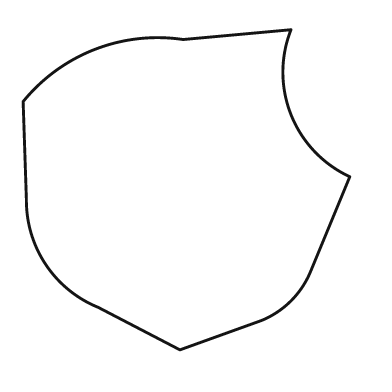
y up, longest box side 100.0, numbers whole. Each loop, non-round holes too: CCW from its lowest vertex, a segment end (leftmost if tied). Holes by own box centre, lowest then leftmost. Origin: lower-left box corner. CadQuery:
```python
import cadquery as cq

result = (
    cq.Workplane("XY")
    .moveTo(48.0, 0.0)
    .lineTo(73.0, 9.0)
    .threePointArc((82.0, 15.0), (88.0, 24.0))
    .lineTo(100.0, 53.0)
    .threePointArc((82.0, 72.0), (82.0, 98.0))
    .lineTo(49.0, 95.0)
    .threePointArc((22.0, 92.0), (0.0, 76.0))
    .lineTo(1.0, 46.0)
    .threePointArc((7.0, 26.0), (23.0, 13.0))
    .close()
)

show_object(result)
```